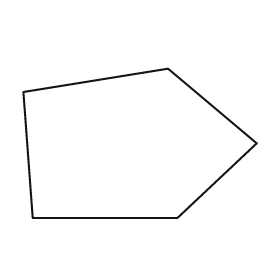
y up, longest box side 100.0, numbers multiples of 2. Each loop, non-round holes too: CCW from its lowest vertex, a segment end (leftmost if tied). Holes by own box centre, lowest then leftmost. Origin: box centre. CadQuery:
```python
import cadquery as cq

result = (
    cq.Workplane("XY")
    .moveTo(-46.0, -32.0)
    .lineTo(16.0, -32.0)
    .lineTo(50.0, 0.0)
    .lineTo(12.0, 32.0)
    .lineTo(-50.0, 22.0)
    .close()
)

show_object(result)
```